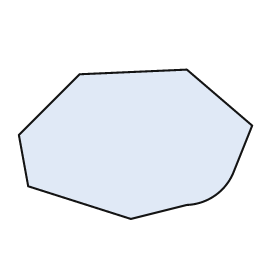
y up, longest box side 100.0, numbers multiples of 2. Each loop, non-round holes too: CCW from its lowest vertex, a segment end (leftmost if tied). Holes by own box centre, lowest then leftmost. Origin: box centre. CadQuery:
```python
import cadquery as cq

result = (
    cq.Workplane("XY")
    .moveTo(-2.0, -32.0)
    .lineTo(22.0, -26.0)
    .threePointArc((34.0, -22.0), (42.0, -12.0))
    .lineTo(50.0, 8.0)
    .lineTo(22.0, 32.0)
    .lineTo(-24.0, 30.0)
    .lineTo(-50.0, 4.0)
    .lineTo(-46.0, -18.0)
    .close()
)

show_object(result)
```